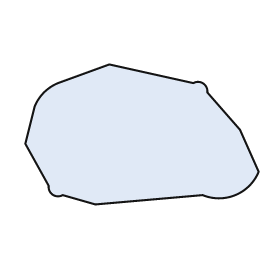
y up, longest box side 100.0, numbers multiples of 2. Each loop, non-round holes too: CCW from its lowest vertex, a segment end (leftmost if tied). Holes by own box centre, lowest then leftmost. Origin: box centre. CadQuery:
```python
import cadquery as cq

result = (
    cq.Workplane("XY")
    .moveTo(-20.0, -30.0)
    .lineTo(26.0, -26.0)
    .threePointArc((40.0, -26.0), (50.0, -16.0))
    .lineTo(42.0, 2.0)
    .lineTo(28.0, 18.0)
    .threePointArc((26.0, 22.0), (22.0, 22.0))
    .lineTo(-14.0, 30.0)
    .lineTo(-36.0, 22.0)
    .threePointArc((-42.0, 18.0), (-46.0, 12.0))
    .lineTo(-50.0, -4.0)
    .lineTo(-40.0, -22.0)
    .threePointArc((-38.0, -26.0), (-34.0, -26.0))
    .close()
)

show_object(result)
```